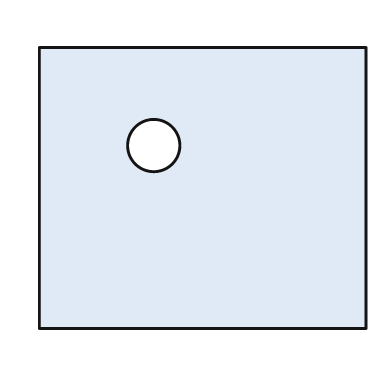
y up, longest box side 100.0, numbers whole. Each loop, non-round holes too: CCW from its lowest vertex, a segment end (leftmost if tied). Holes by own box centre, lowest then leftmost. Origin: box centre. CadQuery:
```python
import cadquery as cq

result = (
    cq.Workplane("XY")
    .moveTo(-50.0, -43.0)
    .lineTo(50.0, -43.0)
    .lineTo(50.0, 43.0)
    .lineTo(-50.0, 43.0)
    .close()
    .moveTo(-15.0, 13.0)
    .circle(8.0)
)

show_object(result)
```